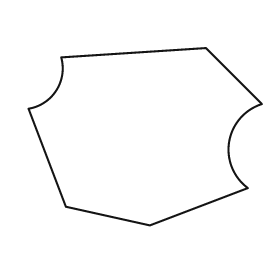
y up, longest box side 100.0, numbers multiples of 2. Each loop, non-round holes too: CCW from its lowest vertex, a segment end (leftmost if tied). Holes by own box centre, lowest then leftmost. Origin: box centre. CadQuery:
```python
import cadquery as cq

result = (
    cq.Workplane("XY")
    .moveTo(2.0, -38.0)
    .lineTo(44.0, -22.0)
    .threePointArc((36.0, -2.0), (50.0, 14.0))
    .lineTo(26.0, 38.0)
    .lineTo(-36.0, 34.0)
    .threePointArc((-38.0, 20.0), (-50.0, 12.0))
    .lineTo(-34.0, -30.0)
    .close()
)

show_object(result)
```